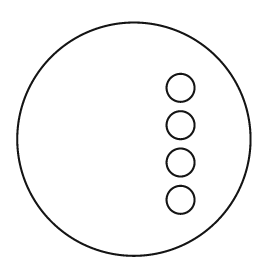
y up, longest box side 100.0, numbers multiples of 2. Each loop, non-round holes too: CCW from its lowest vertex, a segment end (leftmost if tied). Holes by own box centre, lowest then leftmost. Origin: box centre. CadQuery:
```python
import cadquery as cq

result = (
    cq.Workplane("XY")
    .moveTo(0.0, 0.0)
    .circle(50.0)
    .moveTo(20.0, -26.0)
    .circle(6.0)
    .moveTo(20.0, -10.0)
    .circle(6.0)
    .moveTo(20.0, 6.0)
    .circle(6.0)
    .moveTo(20.0, 22.0)
    .circle(6.0)
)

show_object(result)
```